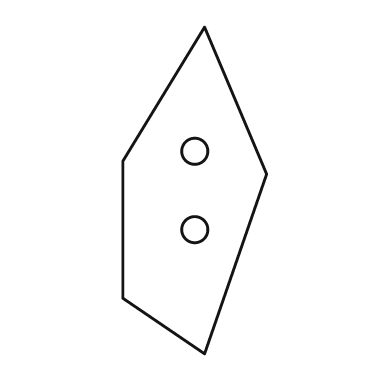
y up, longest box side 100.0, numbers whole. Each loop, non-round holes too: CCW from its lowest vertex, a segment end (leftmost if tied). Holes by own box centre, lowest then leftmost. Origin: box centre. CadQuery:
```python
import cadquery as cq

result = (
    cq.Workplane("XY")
    .moveTo(3.0, -50.0)
    .lineTo(22.0, 5.0)
    .lineTo(3.0, 50.0)
    .lineTo(-22.0, 9.0)
    .lineTo(-22.0, -33.0)
    .close()
    .moveTo(0.0, -12.0)
    .circle(4.0)
    .moveTo(0.0, 12.0)
    .circle(4.0)
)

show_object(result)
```